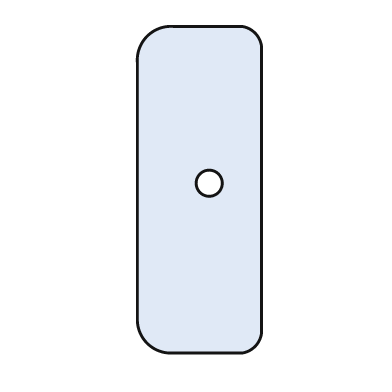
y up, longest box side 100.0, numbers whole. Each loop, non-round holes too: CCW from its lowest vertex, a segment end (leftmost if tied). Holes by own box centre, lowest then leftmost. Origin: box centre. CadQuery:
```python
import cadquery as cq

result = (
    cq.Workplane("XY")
    .moveTo(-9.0, -50.0)
    .lineTo(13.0, -50.0)
    .threePointArc((17.0, -48.0), (19.0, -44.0))
    .lineTo(19.0, 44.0)
    .threePointArc((17.0, 48.0), (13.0, 50.0))
    .lineTo(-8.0, 50.0)
    .threePointArc((-16.0, 47.0), (-19.0, 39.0))
    .lineTo(-19.0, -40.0)
    .threePointArc((-16.0, -47.0), (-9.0, -50.0))
    .close()
    .moveTo(3.0, 2.0)
    .circle(4.0)
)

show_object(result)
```